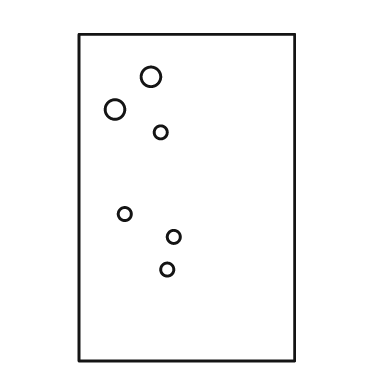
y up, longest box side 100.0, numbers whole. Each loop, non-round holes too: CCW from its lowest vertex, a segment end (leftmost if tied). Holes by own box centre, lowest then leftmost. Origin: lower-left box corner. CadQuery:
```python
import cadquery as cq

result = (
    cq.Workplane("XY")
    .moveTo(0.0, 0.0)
    .lineTo(66.0, 0.0)
    .lineTo(66.0, 100.0)
    .lineTo(0.0, 100.0)
    .close()
    .moveTo(27.0, 28.0)
    .circle(2.0)
    .moveTo(29.0, 38.0)
    .circle(2.0)
    .moveTo(14.0, 45.0)
    .circle(2.0)
    .moveTo(25.0, 70.0)
    .circle(2.0)
    .moveTo(11.0, 77.0)
    .circle(3.0)
    .moveTo(22.0, 87.0)
    .circle(3.0)
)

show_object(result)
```